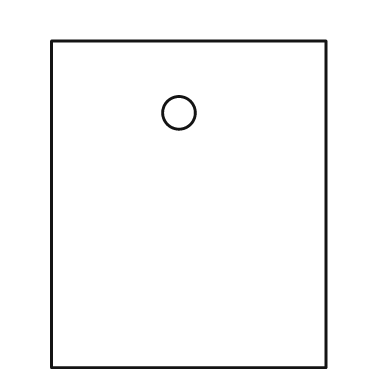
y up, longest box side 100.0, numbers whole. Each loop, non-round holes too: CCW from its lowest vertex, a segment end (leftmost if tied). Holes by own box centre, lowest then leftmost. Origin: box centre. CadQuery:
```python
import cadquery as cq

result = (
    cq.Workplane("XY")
    .moveTo(-42.0, -50.0)
    .lineTo(42.0, -50.0)
    .lineTo(42.0, 50.0)
    .lineTo(-42.0, 50.0)
    .close()
    .moveTo(-3.0, 28.0)
    .circle(5.0)
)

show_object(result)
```